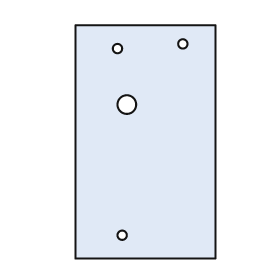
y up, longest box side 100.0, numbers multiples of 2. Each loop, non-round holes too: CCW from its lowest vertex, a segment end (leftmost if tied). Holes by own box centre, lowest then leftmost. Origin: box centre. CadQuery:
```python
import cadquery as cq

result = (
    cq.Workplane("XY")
    .moveTo(-30.0, -50.0)
    .lineTo(30.0, -50.0)
    .lineTo(30.0, 50.0)
    .lineTo(-30.0, 50.0)
    .close()
    .moveTo(-10.0, -40.0)
    .circle(2.0)
    .moveTo(-8.0, 16.0)
    .circle(4.0)
    .moveTo(-12.0, 40.0)
    .circle(2.0)
    .moveTo(16.0, 42.0)
    .circle(2.0)
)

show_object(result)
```